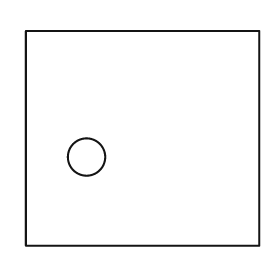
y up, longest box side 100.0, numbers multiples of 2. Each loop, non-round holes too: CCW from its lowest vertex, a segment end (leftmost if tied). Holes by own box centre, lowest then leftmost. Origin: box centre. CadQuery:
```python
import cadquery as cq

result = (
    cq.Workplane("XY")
    .moveTo(-50.0, -46.0)
    .lineTo(50.0, -46.0)
    .lineTo(50.0, 46.0)
    .lineTo(-50.0, 46.0)
    .close()
    .moveTo(-24.0, -8.0)
    .circle(8.0)
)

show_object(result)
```